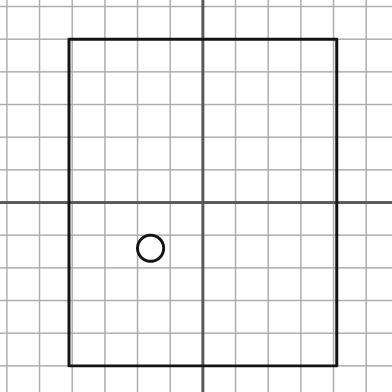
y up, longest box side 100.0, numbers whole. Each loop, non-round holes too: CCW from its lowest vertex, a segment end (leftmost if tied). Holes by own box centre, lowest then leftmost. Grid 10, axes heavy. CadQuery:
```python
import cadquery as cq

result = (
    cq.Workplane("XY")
    .moveTo(-41.0, -50.0)
    .lineTo(41.0, -50.0)
    .lineTo(41.0, 50.0)
    .lineTo(-41.0, 50.0)
    .close()
    .moveTo(-16.0, -14.0)
    .circle(4.0)
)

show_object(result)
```